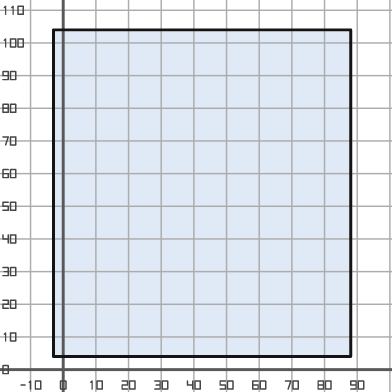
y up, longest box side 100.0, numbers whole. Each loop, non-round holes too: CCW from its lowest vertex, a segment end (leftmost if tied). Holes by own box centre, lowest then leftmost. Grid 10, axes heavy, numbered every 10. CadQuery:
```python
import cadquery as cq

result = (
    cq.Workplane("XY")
    .moveTo(-3.0, 4.0)
    .lineTo(88.0, 4.0)
    .lineTo(88.0, 104.0)
    .lineTo(-3.0, 104.0)
    .close()
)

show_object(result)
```